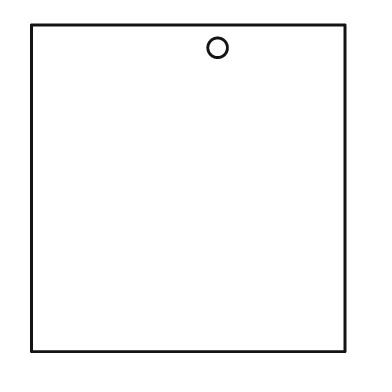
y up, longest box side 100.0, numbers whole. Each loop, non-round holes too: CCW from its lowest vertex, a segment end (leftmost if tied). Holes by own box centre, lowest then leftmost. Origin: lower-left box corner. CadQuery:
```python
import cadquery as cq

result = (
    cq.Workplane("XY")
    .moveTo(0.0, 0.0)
    .lineTo(96.0, 0.0)
    .lineTo(96.0, 100.0)
    .lineTo(0.0, 100.0)
    .close()
    .moveTo(57.0, 93.0)
    .circle(3.0)
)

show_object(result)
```